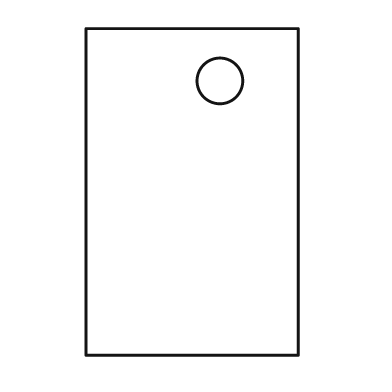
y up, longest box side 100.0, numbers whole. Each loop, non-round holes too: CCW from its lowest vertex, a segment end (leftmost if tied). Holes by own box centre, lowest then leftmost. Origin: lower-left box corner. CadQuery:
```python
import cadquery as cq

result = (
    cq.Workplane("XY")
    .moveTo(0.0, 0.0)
    .lineTo(65.0, 0.0)
    .lineTo(65.0, 100.0)
    .lineTo(0.0, 100.0)
    .close()
    .moveTo(41.0, 84.0)
    .circle(7.0)
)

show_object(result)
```